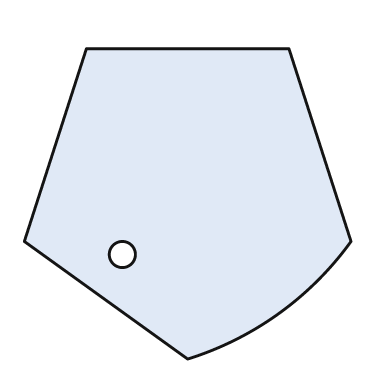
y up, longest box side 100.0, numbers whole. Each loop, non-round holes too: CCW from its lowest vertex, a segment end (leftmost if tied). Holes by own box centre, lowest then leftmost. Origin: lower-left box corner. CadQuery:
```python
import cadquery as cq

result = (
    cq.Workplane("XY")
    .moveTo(50.0, 0.0)
    .threePointArc((78.0, 14.0), (100.0, 36.0))
    .lineTo(81.0, 95.0)
    .lineTo(19.0, 95.0)
    .lineTo(0.0, 36.0)
    .close()
    .moveTo(30.0, 32.0)
    .circle(4.0)
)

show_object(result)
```